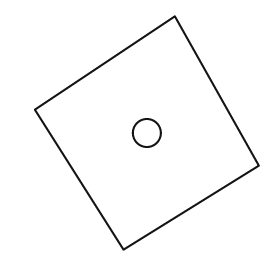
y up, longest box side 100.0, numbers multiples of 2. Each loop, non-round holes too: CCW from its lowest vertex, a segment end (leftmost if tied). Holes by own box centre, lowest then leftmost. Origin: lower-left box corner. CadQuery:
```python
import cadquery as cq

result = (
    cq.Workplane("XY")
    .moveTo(38.0, 0.0)
    .lineTo(96.0, 36.0)
    .lineTo(60.0, 100.0)
    .lineTo(0.0, 60.0)
    .close()
    .moveTo(48.0, 50.0)
    .circle(6.0)
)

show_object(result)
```